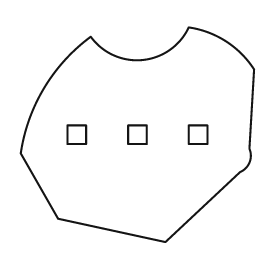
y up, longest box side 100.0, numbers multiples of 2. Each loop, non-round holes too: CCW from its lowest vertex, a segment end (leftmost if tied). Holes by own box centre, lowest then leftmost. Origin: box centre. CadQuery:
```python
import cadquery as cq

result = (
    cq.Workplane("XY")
    .moveTo(12.0, -46.0)
    .lineTo(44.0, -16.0)
    .threePointArc((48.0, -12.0), (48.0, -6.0))
    .lineTo(50.0, 28.0)
    .threePointArc((38.0, 40.0), (22.0, 46.0))
    .threePointArc((2.0, 32.0), (-20.0, 42.0))
    .threePointArc((-40.0, 20.0), (-50.0, -8.0))
    .lineTo(-34.0, -36.0)
    .close()
    .moveTo(-30.0, -4.0)
    .lineTo(-22.0, -4.0)
    .lineTo(-22.0, 4.0)
    .lineTo(-30.0, 4.0)
    .close()
    .moveTo(-4.0, -4.0)
    .lineTo(4.0, -4.0)
    .lineTo(4.0, 4.0)
    .lineTo(-4.0, 4.0)
    .close()
    .moveTo(22.0, -4.0)
    .lineTo(30.0, -4.0)
    .lineTo(30.0, 4.0)
    .lineTo(22.0, 4.0)
    .close()
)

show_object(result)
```